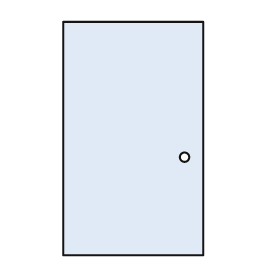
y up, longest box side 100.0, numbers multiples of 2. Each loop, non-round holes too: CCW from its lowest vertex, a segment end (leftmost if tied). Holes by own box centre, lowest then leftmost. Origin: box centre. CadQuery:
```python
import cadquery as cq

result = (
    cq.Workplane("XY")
    .moveTo(-30.0, -50.0)
    .lineTo(30.0, -50.0)
    .lineTo(30.0, 50.0)
    .lineTo(-30.0, 50.0)
    .close()
    .moveTo(22.0, -8.0)
    .circle(2.0)
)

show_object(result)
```